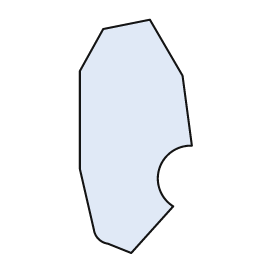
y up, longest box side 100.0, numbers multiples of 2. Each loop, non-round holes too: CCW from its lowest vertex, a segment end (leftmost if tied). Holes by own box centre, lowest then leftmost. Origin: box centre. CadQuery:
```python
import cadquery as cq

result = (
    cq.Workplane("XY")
    .moveTo(-2.0, -50.0)
    .lineTo(16.0, -30.0)
    .threePointArc((10.0, -14.0), (24.0, -4.0))
    .lineTo(20.0, 26.0)
    .lineTo(6.0, 50.0)
    .lineTo(-14.0, 46.0)
    .lineTo(-24.0, 28.0)
    .lineTo(-24.0, -14.0)
    .lineTo(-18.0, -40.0)
    .threePointArc((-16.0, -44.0), (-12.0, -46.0))
    .close()
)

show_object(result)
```